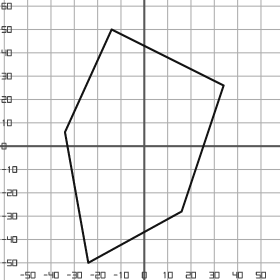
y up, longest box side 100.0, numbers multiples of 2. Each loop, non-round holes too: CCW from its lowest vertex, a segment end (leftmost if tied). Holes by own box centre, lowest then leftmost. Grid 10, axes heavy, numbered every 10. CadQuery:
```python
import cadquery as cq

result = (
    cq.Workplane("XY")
    .moveTo(-24.0, -50.0)
    .lineTo(16.0, -28.0)
    .lineTo(34.0, 26.0)
    .lineTo(-14.0, 50.0)
    .lineTo(-34.0, 6.0)
    .close()
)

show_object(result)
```